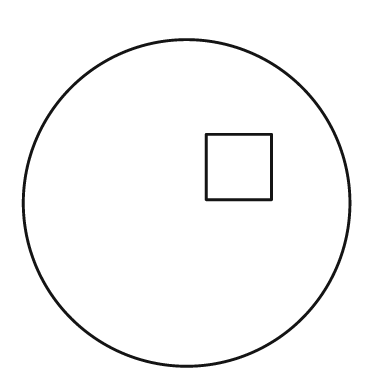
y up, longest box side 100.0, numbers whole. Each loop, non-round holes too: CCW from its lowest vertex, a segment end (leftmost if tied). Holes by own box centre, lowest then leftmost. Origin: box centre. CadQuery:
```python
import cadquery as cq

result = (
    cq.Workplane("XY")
    .moveTo(0.0, 0.0)
    .circle(50.0)
    .moveTo(6.0, 1.0)
    .lineTo(26.0, 1.0)
    .lineTo(26.0, 21.0)
    .lineTo(6.0, 21.0)
    .close()
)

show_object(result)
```